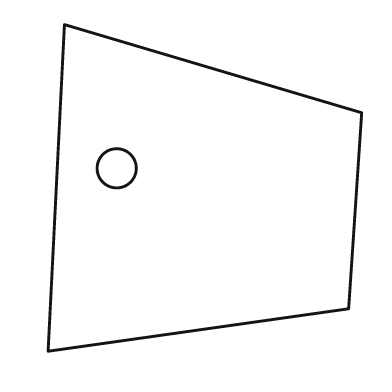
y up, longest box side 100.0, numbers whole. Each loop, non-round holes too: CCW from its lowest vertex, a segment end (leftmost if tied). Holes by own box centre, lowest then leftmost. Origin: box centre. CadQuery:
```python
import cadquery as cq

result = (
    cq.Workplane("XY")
    .moveTo(-48.0, -50.0)
    .lineTo(44.0, -37.0)
    .lineTo(48.0, 23.0)
    .lineTo(-43.0, 50.0)
    .close()
    .moveTo(-27.0, 6.0)
    .circle(6.0)
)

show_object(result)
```